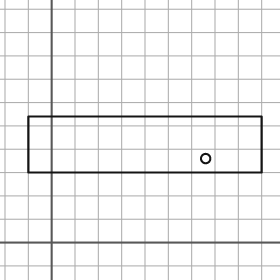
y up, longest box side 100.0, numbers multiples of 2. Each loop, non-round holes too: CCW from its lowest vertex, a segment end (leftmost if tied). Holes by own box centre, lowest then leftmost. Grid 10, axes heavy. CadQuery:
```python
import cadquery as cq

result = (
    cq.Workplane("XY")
    .moveTo(-10.0, 30.0)
    .lineTo(90.0, 30.0)
    .lineTo(90.0, 54.0)
    .lineTo(-10.0, 54.0)
    .close()
    .moveTo(66.0, 36.0)
    .circle(2.0)
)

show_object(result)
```